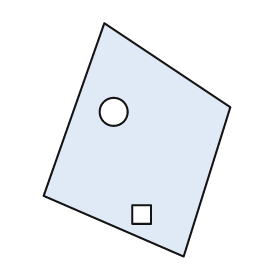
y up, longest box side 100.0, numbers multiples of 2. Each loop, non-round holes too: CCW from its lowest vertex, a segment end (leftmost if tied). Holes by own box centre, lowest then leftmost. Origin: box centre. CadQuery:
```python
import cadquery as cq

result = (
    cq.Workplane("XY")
    .moveTo(20.0, -50.0)
    .lineTo(40.0, 14.0)
    .lineTo(-14.0, 50.0)
    .lineTo(-40.0, -24.0)
    .close()
    .moveTo(-2.0, -36.0)
    .lineTo(6.0, -36.0)
    .lineTo(6.0, -28.0)
    .lineTo(-2.0, -28.0)
    .close()
    .moveTo(-10.0, 12.0)
    .circle(6.0)
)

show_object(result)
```